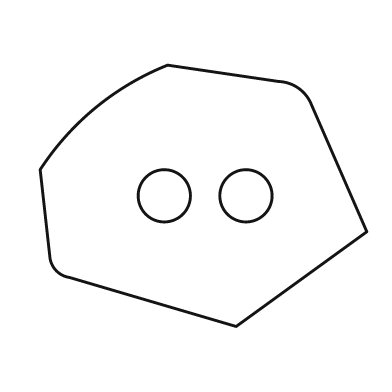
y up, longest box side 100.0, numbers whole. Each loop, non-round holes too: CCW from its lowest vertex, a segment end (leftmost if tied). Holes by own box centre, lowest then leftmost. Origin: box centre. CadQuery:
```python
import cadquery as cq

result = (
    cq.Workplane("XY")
    .moveTo(10.0, -40.0)
    .lineTo(50.0, -11.0)
    .lineTo(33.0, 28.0)
    .threePointArc((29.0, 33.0), (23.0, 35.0))
    .lineTo(-11.0, 40.0)
    .threePointArc((-33.0, 27.0), (-50.0, 8.0))
    .lineTo(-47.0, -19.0)
    .threePointArc((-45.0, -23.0), (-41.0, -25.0))
    .close()
    .moveTo(-12.0, 0.0)
    .circle(8.0)
    .moveTo(13.0, 0.0)
    .circle(8.0)
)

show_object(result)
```